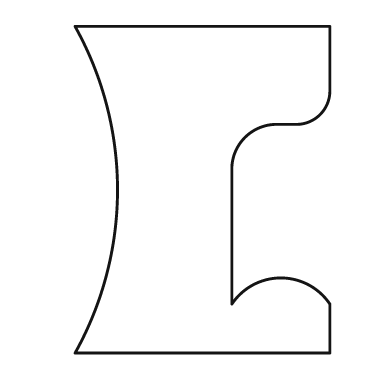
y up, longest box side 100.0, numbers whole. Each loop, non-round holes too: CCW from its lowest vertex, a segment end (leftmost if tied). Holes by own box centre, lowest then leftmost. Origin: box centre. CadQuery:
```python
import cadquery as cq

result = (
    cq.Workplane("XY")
    .moveTo(-39.0, -50.0)
    .lineTo(39.0, -50.0)
    .lineTo(39.0, -35.0)
    .threePointArc((24.0, -27.0), (9.0, -35.0))
    .lineTo(9.0, 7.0)
    .threePointArc((13.0, 16.0), (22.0, 20.0))
    .lineTo(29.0, 20.0)
    .threePointArc((36.0, 23.0), (39.0, 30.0))
    .lineTo(39.0, 50.0)
    .lineTo(-39.0, 50.0)
    .threePointArc((-26.0, 0.0), (-39.0, -50.0))
    .close()
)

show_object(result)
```